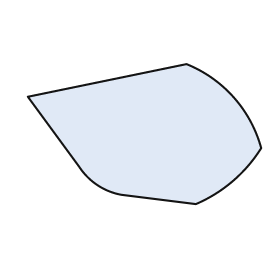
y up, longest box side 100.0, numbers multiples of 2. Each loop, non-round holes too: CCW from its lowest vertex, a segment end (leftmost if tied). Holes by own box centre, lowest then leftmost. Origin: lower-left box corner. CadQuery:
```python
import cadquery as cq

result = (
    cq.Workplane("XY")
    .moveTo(72.0, 0.0)
    .threePointArc((88.0, 10.0), (100.0, 24.0))
    .threePointArc((88.0, 46.0), (68.0, 60.0))
    .lineTo(0.0, 46.0)
    .lineTo(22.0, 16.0)
    .threePointArc((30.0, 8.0), (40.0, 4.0))
    .close()
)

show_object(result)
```